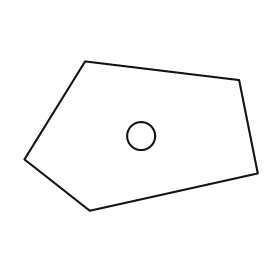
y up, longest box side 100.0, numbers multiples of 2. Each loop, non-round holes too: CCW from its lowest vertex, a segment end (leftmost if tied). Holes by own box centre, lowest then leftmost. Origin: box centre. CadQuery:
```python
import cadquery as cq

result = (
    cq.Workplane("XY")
    .moveTo(-22.0, -32.0)
    .lineTo(50.0, -16.0)
    .lineTo(42.0, 24.0)
    .lineTo(-24.0, 32.0)
    .lineTo(-50.0, -10.0)
    .close()
    .moveTo(0.0, 0.0)
    .circle(6.0)
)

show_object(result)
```